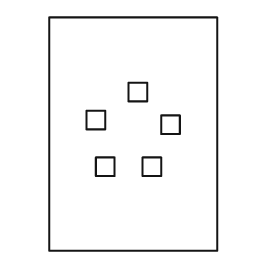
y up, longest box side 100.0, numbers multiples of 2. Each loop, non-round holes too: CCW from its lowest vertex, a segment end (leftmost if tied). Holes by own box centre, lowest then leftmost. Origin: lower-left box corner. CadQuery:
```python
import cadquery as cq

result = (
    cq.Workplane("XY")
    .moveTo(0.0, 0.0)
    .lineTo(72.0, 0.0)
    .lineTo(72.0, 100.0)
    .lineTo(0.0, 100.0)
    .close()
    .moveTo(20.0, 32.0)
    .lineTo(28.0, 32.0)
    .lineTo(28.0, 40.0)
    .lineTo(20.0, 40.0)
    .close()
    .moveTo(40.0, 32.0)
    .lineTo(48.0, 32.0)
    .lineTo(48.0, 40.0)
    .lineTo(40.0, 40.0)
    .close()
    .moveTo(48.0, 50.0)
    .lineTo(56.0, 50.0)
    .lineTo(56.0, 58.0)
    .lineTo(48.0, 58.0)
    .close()
    .moveTo(16.0, 52.0)
    .lineTo(24.0, 52.0)
    .lineTo(24.0, 60.0)
    .lineTo(16.0, 60.0)
    .close()
    .moveTo(34.0, 64.0)
    .lineTo(42.0, 64.0)
    .lineTo(42.0, 72.0)
    .lineTo(34.0, 72.0)
    .close()
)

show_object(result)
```